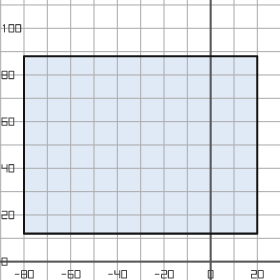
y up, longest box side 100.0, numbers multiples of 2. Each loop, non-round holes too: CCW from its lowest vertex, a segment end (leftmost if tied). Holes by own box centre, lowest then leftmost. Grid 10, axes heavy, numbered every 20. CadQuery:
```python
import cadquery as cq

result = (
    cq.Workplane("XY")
    .moveTo(-80.0, 12.0)
    .lineTo(20.0, 12.0)
    .lineTo(20.0, 88.0)
    .lineTo(-80.0, 88.0)
    .close()
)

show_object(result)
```